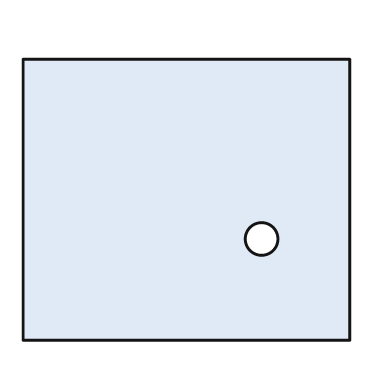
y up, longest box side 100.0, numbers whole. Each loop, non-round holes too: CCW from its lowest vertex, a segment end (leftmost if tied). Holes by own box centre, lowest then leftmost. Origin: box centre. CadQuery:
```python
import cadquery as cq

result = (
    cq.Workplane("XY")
    .moveTo(-50.0, -43.0)
    .lineTo(50.0, -43.0)
    .lineTo(50.0, 43.0)
    .lineTo(-50.0, 43.0)
    .close()
    .moveTo(23.0, -12.0)
    .circle(5.0)
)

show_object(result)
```